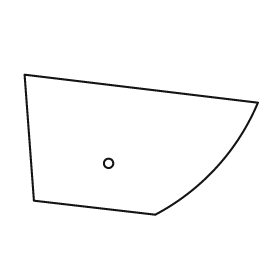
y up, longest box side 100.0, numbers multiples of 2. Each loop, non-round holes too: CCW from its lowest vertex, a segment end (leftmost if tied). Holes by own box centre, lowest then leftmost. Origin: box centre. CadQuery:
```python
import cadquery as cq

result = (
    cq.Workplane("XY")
    .moveTo(6.0, -30.0)
    .threePointArc((32.0, -10.0), (50.0, 18.0))
    .lineTo(-50.0, 30.0)
    .lineTo(-46.0, -24.0)
    .close()
    .moveTo(-14.0, -8.0)
    .circle(2.0)
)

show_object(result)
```